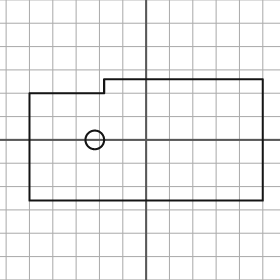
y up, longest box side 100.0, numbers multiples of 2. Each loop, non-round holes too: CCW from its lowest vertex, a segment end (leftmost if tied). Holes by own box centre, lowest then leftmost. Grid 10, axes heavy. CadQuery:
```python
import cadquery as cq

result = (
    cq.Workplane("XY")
    .moveTo(-50.0, -26.0)
    .lineTo(50.0, -26.0)
    .lineTo(50.0, 26.0)
    .lineTo(-18.0, 26.0)
    .lineTo(-18.0, 20.0)
    .lineTo(-50.0, 20.0)
    .close()
    .moveTo(-22.0, 0.0)
    .circle(4.0)
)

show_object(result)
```